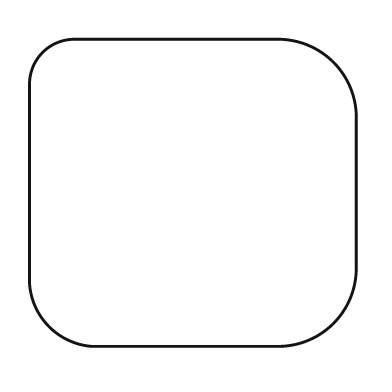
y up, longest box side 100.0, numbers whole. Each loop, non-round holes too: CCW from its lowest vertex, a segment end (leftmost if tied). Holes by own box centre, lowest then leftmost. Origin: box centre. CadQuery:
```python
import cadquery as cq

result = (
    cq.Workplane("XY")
    .moveTo(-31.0, -47.0)
    .lineTo(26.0, -47.0)
    .threePointArc((43.0, -40.0), (50.0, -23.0))
    .lineTo(50.0, 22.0)
    .threePointArc((43.0, 40.0), (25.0, 47.0))
    .lineTo(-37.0, 47.0)
    .threePointArc((-46.0, 43.0), (-50.0, 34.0))
    .lineTo(-50.0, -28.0)
    .threePointArc((-44.0, -41.0), (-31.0, -47.0))
    .close()
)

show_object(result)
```